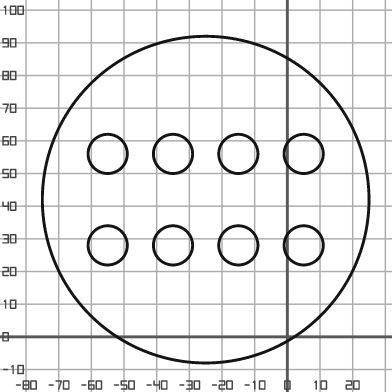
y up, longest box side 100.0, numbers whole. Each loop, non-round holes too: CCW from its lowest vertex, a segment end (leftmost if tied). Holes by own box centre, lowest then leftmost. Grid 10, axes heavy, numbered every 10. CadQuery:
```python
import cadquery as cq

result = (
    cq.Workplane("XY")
    .moveTo(-25.0, 42.0)
    .circle(50.0)
    .moveTo(-55.0, 28.0)
    .circle(6.0)
    .moveTo(-35.0, 28.0)
    .circle(6.0)
    .moveTo(-15.0, 28.0)
    .circle(6.0)
    .moveTo(5.0, 28.0)
    .circle(6.0)
    .moveTo(-55.0, 56.0)
    .circle(6.0)
    .moveTo(-35.0, 56.0)
    .circle(6.0)
    .moveTo(-15.0, 56.0)
    .circle(6.0)
    .moveTo(5.0, 56.0)
    .circle(6.0)
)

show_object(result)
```